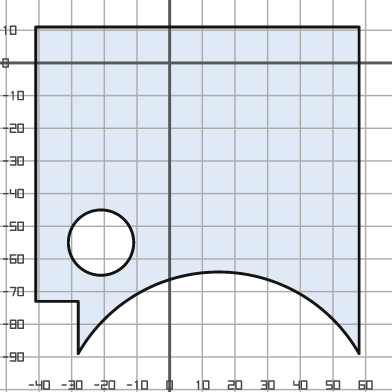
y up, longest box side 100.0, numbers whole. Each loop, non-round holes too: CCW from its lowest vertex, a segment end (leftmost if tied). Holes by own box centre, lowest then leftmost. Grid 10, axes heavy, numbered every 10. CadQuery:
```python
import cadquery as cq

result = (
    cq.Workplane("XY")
    .moveTo(-28.0, -89.0)
    .threePointArc((15.0, -64.0), (58.0, -89.0))
    .lineTo(58.0, 11.0)
    .lineTo(-41.0, 11.0)
    .lineTo(-41.0, -73.0)
    .lineTo(-28.0, -73.0)
    .close()
    .moveTo(-21.0, -55.0)
    .circle(10.0)
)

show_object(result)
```